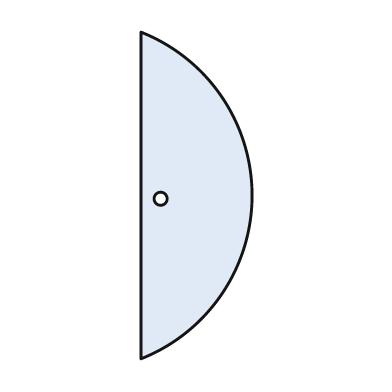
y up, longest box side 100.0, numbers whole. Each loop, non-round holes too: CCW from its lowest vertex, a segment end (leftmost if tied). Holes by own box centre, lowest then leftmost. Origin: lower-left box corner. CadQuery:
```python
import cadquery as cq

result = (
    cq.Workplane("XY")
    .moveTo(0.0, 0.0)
    .threePointArc((34.0, 50.0), (0.0, 100.0))
    .close()
    .moveTo(6.0, 49.0)
    .circle(2.0)
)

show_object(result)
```